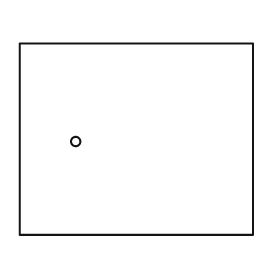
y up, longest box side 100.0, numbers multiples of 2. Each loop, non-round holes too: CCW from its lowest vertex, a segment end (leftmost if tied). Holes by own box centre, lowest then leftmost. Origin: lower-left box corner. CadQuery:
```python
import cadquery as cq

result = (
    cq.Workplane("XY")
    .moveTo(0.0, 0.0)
    .lineTo(100.0, 0.0)
    .lineTo(100.0, 82.0)
    .lineTo(0.0, 82.0)
    .close()
    .moveTo(24.0, 40.0)
    .circle(2.0)
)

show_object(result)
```